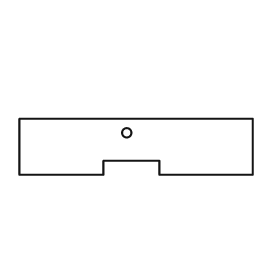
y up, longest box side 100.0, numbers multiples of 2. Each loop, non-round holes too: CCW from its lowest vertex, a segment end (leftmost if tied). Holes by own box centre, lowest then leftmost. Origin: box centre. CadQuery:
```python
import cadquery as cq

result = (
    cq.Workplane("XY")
    .moveTo(-50.0, -12.0)
    .lineTo(-14.0, -12.0)
    .lineTo(-14.0, -6.0)
    .lineTo(10.0, -6.0)
    .lineTo(10.0, -12.0)
    .lineTo(50.0, -12.0)
    .lineTo(50.0, 12.0)
    .lineTo(-50.0, 12.0)
    .close()
    .moveTo(-4.0, 6.0)
    .circle(2.0)
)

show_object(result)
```